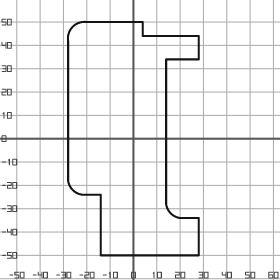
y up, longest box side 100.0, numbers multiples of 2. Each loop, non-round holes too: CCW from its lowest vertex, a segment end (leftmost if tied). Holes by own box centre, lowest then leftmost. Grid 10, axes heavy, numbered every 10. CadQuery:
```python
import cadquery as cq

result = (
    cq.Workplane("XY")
    .moveTo(-14.0, -50.0)
    .lineTo(28.0, -50.0)
    .lineTo(28.0, -34.0)
    .lineTo(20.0, -34.0)
    .threePointArc((16.0, -32.0), (14.0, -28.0))
    .lineTo(14.0, 34.0)
    .lineTo(28.0, 34.0)
    .lineTo(28.0, 44.0)
    .lineTo(4.0, 44.0)
    .lineTo(4.0, 50.0)
    .lineTo(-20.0, 50.0)
    .threePointArc((-26.0, 48.0), (-28.0, 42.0))
    .lineTo(-28.0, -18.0)
    .threePointArc((-26.0, -22.0), (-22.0, -24.0))
    .lineTo(-14.0, -24.0)
    .close()
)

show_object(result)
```